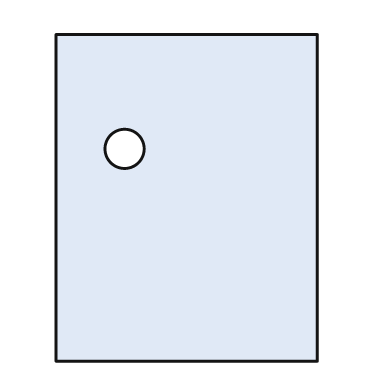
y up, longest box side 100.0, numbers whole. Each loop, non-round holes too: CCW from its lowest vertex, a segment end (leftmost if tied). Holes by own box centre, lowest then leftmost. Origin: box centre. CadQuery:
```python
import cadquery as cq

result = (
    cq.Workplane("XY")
    .moveTo(-40.0, -50.0)
    .lineTo(40.0, -50.0)
    .lineTo(40.0, 50.0)
    .lineTo(-40.0, 50.0)
    .close()
    .moveTo(-19.0, 15.0)
    .circle(6.0)
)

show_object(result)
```